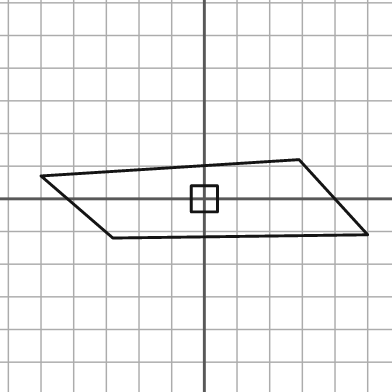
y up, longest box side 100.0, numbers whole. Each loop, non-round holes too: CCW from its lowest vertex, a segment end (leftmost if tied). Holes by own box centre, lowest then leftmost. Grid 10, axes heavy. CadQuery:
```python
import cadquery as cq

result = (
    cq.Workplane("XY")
    .moveTo(-28.0, -12.0)
    .lineTo(50.0, -11.0)
    .lineTo(29.0, 12.0)
    .lineTo(-50.0, 7.0)
    .close()
    .moveTo(-4.0, -4.0)
    .lineTo(4.0, -4.0)
    .lineTo(4.0, 4.0)
    .lineTo(-4.0, 4.0)
    .close()
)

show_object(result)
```